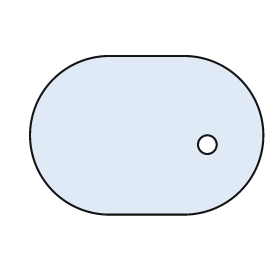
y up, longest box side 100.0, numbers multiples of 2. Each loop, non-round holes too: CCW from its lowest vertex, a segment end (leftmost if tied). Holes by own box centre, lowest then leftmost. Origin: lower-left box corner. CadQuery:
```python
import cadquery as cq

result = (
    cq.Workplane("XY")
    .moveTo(34.0, 0.0)
    .lineTo(66.0, 0.0)
    .threePointArc((100.0, 34.0), (66.0, 68.0))
    .lineTo(34.0, 68.0)
    .threePointArc((0.0, 34.0), (34.0, 0.0))
    .close()
    .moveTo(76.0, 30.0)
    .circle(4.0)
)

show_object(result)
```